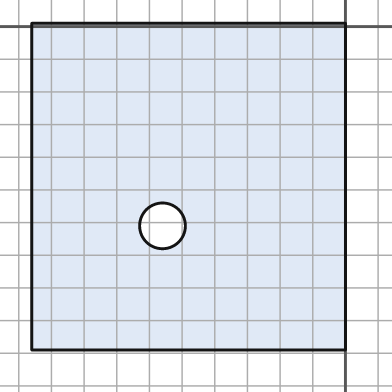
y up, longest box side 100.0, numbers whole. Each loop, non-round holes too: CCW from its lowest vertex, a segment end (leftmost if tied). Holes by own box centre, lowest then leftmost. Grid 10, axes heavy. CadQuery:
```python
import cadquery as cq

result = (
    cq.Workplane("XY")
    .moveTo(-96.0, -99.0)
    .lineTo(0.0, -99.0)
    .lineTo(0.0, 1.0)
    .lineTo(-96.0, 1.0)
    .close()
    .moveTo(-56.0, -61.0)
    .circle(7.0)
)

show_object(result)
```